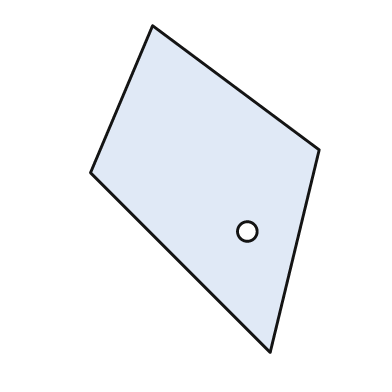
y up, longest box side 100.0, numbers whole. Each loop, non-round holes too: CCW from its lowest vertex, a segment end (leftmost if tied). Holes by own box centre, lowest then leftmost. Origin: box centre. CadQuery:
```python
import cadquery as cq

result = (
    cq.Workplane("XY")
    .moveTo(20.0, -50.0)
    .lineTo(35.0, 12.0)
    .lineTo(-16.0, 50.0)
    .lineTo(-35.0, 5.0)
    .close()
    .moveTo(13.0, -13.0)
    .circle(3.0)
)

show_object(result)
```